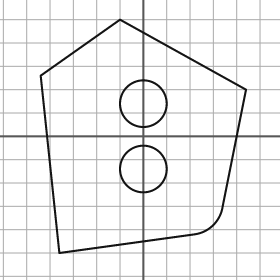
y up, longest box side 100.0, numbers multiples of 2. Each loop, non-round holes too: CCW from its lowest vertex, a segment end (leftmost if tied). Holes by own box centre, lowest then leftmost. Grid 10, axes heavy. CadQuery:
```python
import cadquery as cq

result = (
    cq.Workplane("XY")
    .moveTo(-36.0, -50.0)
    .lineTo(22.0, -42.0)
    .threePointArc((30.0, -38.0), (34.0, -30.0))
    .lineTo(44.0, 20.0)
    .lineTo(-10.0, 50.0)
    .lineTo(-44.0, 26.0)
    .close()
    .moveTo(0.0, -14.0)
    .circle(10.0)
    .moveTo(0.0, 14.0)
    .circle(10.0)
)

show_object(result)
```